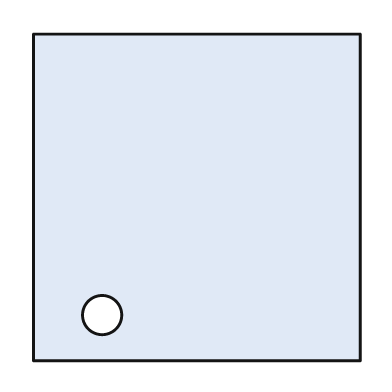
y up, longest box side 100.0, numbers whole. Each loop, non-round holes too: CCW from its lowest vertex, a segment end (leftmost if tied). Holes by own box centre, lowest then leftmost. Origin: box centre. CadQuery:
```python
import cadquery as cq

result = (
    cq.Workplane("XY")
    .moveTo(-50.0, -50.0)
    .lineTo(50.0, -50.0)
    .lineTo(50.0, 50.0)
    .lineTo(-50.0, 50.0)
    .close()
    .moveTo(-29.0, -36.0)
    .circle(6.0)
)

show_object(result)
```